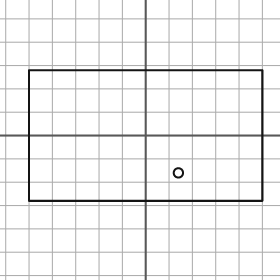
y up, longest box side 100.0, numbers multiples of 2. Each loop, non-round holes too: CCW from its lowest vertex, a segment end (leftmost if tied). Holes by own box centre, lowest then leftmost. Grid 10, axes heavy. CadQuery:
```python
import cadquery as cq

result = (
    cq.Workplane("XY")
    .moveTo(-50.0, -28.0)
    .lineTo(50.0, -28.0)
    .lineTo(50.0, 28.0)
    .lineTo(-50.0, 28.0)
    .close()
    .moveTo(14.0, -16.0)
    .circle(2.0)
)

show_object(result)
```